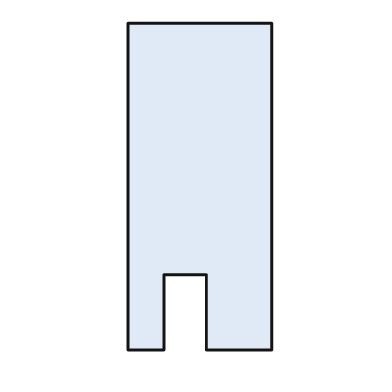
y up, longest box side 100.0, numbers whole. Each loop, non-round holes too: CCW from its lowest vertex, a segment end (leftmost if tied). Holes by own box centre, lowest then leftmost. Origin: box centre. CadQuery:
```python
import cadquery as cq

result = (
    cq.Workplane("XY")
    .moveTo(-22.0, -50.0)
    .lineTo(-11.0, -50.0)
    .lineTo(-11.0, -27.0)
    .lineTo(2.0, -27.0)
    .lineTo(2.0, -50.0)
    .lineTo(22.0, -50.0)
    .lineTo(22.0, 50.0)
    .lineTo(-22.0, 50.0)
    .close()
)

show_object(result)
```